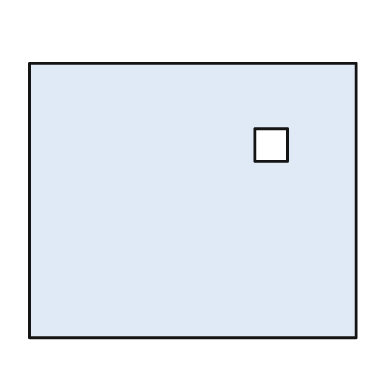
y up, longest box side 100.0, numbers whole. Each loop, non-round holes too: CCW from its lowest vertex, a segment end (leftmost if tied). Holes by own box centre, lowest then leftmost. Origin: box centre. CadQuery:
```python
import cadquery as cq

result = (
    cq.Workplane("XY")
    .moveTo(-50.0, -42.0)
    .lineTo(50.0, -42.0)
    .lineTo(50.0, 42.0)
    .lineTo(-50.0, 42.0)
    .close()
    .moveTo(19.0, 12.0)
    .lineTo(29.0, 12.0)
    .lineTo(29.0, 22.0)
    .lineTo(19.0, 22.0)
    .close()
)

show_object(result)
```